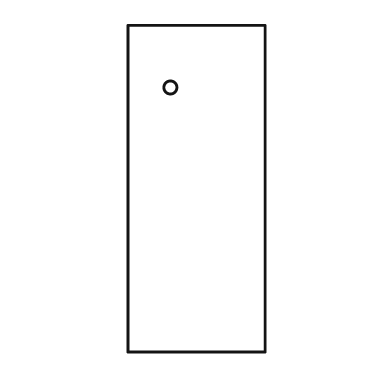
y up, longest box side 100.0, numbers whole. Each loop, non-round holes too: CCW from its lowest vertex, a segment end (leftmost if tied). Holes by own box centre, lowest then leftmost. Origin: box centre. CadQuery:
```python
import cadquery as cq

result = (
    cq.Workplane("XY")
    .moveTo(-21.0, -50.0)
    .lineTo(21.0, -50.0)
    .lineTo(21.0, 50.0)
    .lineTo(-21.0, 50.0)
    .close()
    .moveTo(-8.0, 31.0)
    .circle(2.0)
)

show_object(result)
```